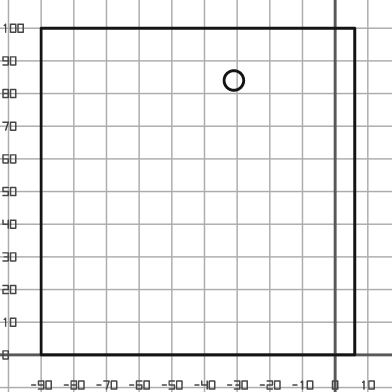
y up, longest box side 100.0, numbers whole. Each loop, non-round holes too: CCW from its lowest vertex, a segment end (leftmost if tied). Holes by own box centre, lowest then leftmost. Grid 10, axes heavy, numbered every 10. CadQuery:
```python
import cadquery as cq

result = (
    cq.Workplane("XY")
    .moveTo(-90.0, 0.0)
    .lineTo(6.0, 0.0)
    .lineTo(6.0, 100.0)
    .lineTo(-90.0, 100.0)
    .close()
    .moveTo(-31.0, 84.0)
    .circle(3.0)
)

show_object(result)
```